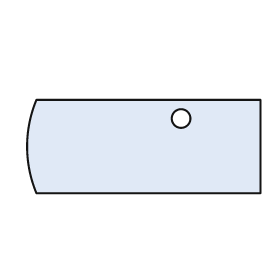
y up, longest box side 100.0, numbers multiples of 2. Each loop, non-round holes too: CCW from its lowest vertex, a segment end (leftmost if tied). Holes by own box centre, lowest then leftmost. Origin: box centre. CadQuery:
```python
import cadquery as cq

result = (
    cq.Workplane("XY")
    .moveTo(-46.0, -20.0)
    .lineTo(50.0, -20.0)
    .lineTo(50.0, 20.0)
    .lineTo(-46.0, 20.0)
    .threePointArc((-50.0, 0.0), (-46.0, -20.0))
    .close()
    .moveTo(16.0, 12.0)
    .circle(4.0)
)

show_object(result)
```